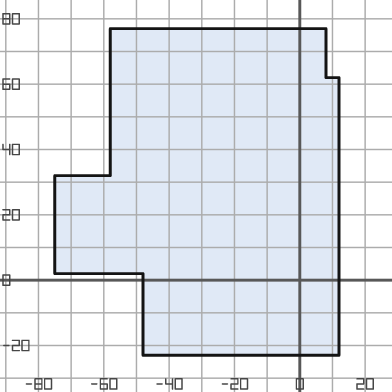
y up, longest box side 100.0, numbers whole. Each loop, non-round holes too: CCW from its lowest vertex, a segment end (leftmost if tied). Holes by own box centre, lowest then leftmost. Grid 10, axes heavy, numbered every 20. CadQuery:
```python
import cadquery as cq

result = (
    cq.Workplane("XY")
    .moveTo(-48.0, -23.0)
    .lineTo(12.0, -23.0)
    .lineTo(12.0, 62.0)
    .lineTo(8.0, 62.0)
    .lineTo(8.0, 77.0)
    .lineTo(-58.0, 77.0)
    .lineTo(-58.0, 32.0)
    .lineTo(-75.0, 32.0)
    .lineTo(-75.0, 2.0)
    .lineTo(-48.0, 2.0)
    .close()
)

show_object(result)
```